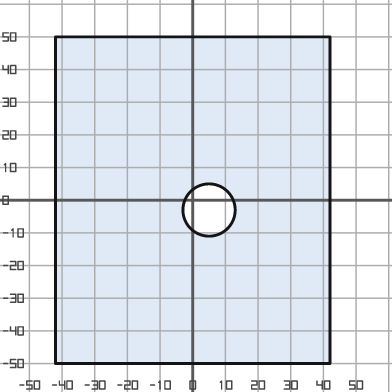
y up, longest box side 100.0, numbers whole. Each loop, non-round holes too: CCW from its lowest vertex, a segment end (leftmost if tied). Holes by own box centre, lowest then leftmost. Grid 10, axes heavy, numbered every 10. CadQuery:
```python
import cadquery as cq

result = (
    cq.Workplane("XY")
    .moveTo(-42.0, -50.0)
    .lineTo(42.0, -50.0)
    .lineTo(42.0, 50.0)
    .lineTo(-42.0, 50.0)
    .close()
    .moveTo(5.0, -3.0)
    .circle(8.0)
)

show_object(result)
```